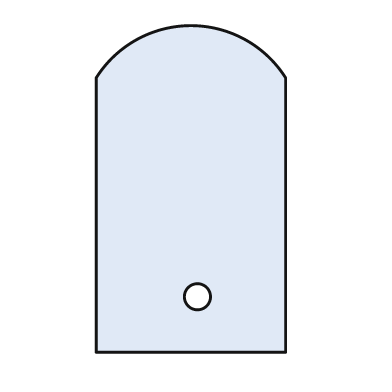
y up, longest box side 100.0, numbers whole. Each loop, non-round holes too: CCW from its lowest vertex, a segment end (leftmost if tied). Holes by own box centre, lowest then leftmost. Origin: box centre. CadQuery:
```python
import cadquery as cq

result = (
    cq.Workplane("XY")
    .moveTo(-29.0, -50.0)
    .lineTo(29.0, -50.0)
    .lineTo(29.0, 34.0)
    .threePointArc((0.0, 50.0), (-29.0, 34.0))
    .close()
    .moveTo(2.0, -33.0)
    .circle(4.0)
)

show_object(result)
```